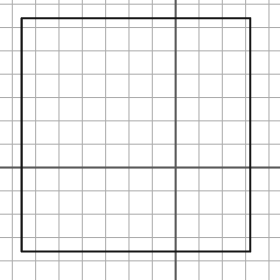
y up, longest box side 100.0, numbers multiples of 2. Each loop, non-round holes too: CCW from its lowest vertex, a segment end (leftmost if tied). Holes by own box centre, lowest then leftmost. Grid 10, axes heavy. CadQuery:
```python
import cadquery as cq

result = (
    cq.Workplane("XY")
    .moveTo(-66.0, -36.0)
    .lineTo(32.0, -36.0)
    .lineTo(32.0, 64.0)
    .lineTo(-66.0, 64.0)
    .close()
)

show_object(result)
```